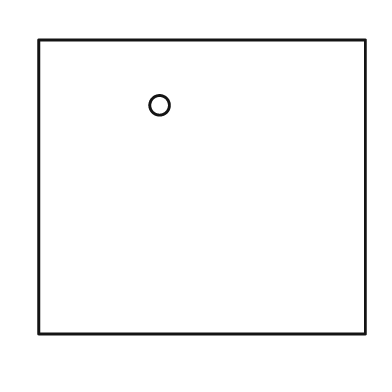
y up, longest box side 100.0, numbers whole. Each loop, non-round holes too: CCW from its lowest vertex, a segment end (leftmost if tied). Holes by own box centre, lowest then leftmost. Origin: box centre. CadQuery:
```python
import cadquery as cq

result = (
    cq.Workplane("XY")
    .moveTo(-50.0, -45.0)
    .lineTo(50.0, -45.0)
    .lineTo(50.0, 45.0)
    .lineTo(-50.0, 45.0)
    .close()
    .moveTo(-13.0, 25.0)
    .circle(3.0)
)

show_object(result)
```